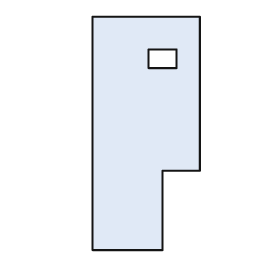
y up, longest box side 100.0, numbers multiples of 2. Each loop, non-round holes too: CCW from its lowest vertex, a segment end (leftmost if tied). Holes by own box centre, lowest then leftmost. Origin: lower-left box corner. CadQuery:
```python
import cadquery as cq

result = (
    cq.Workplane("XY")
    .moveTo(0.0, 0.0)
    .lineTo(30.0, 0.0)
    .lineTo(30.0, 34.0)
    .lineTo(46.0, 34.0)
    .lineTo(46.0, 100.0)
    .lineTo(0.0, 100.0)
    .close()
    .moveTo(24.0, 78.0)
    .lineTo(36.0, 78.0)
    .lineTo(36.0, 86.0)
    .lineTo(24.0, 86.0)
    .close()
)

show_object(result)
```